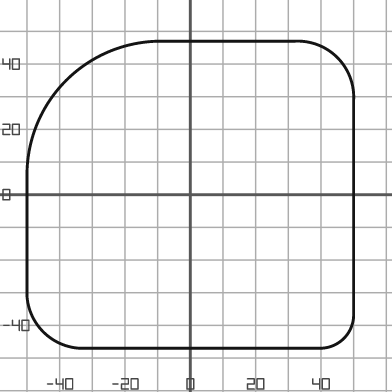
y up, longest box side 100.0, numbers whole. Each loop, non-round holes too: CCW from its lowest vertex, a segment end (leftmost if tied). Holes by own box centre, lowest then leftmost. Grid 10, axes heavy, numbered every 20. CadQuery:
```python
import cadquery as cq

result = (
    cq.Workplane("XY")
    .moveTo(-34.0, -47.0)
    .lineTo(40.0, -47.0)
    .threePointArc((47.0, -44.0), (50.0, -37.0))
    .lineTo(50.0, 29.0)
    .threePointArc((45.0, 42.0), (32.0, 47.0))
    .lineTo(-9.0, 47.0)
    .threePointArc((-38.0, 35.0), (-50.0, 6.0))
    .lineTo(-50.0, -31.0)
    .threePointArc((-45.0, -42.0), (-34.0, -47.0))
    .close()
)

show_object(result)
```